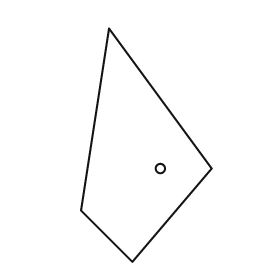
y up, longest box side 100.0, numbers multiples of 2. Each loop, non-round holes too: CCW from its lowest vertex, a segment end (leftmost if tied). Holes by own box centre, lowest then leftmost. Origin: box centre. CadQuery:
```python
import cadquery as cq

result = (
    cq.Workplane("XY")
    .moveTo(-6.0, -50.0)
    .lineTo(28.0, -10.0)
    .lineTo(-16.0, 50.0)
    .lineTo(-28.0, -28.0)
    .close()
    .moveTo(6.0, -10.0)
    .circle(2.0)
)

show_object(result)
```